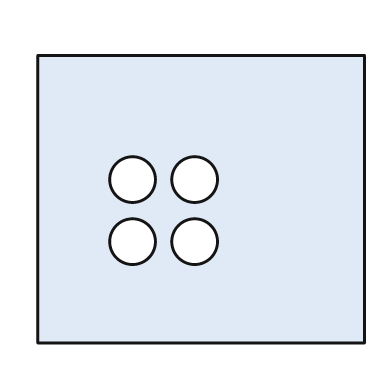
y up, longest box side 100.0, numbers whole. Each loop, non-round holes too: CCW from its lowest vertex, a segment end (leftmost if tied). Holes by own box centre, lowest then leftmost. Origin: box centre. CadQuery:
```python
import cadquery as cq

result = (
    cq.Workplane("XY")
    .moveTo(-50.0, -44.0)
    .lineTo(50.0, -44.0)
    .lineTo(50.0, 44.0)
    .lineTo(-50.0, 44.0)
    .close()
    .moveTo(-21.0, -13.0)
    .circle(7.0)
    .moveTo(-2.0, -13.0)
    .circle(7.0)
    .moveTo(-21.0, 6.0)
    .circle(7.0)
    .moveTo(-2.0, 6.0)
    .circle(7.0)
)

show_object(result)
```